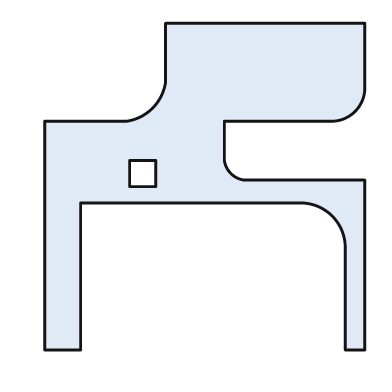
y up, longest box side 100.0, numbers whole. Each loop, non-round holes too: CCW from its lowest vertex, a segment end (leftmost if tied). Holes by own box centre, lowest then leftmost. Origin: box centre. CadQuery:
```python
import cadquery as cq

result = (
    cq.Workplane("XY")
    .moveTo(-49.0, -50.0)
    .lineTo(-38.0, -50.0)
    .lineTo(-38.0, -5.0)
    .lineTo(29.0, -5.0)
    .threePointArc((39.0, -9.0), (43.0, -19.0))
    .lineTo(43.0, -50.0)
    .lineTo(49.0, -50.0)
    .lineTo(49.0, 2.0)
    .lineTo(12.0, 2.0)
    .threePointArc((8.0, 4.0), (6.0, 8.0))
    .lineTo(6.0, 20.0)
    .lineTo(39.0, 20.0)
    .threePointArc((46.0, 23.0), (49.0, 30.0))
    .lineTo(49.0, 50.0)
    .lineTo(-12.0, 50.0)
    .lineTo(-12.0, 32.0)
    .threePointArc((-16.0, 24.0), (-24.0, 20.0))
    .lineTo(-49.0, 20.0)
    .close()
    .moveTo(-23.0, 0.0)
    .lineTo(-15.0, 0.0)
    .lineTo(-15.0, 8.0)
    .lineTo(-23.0, 8.0)
    .close()
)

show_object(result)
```